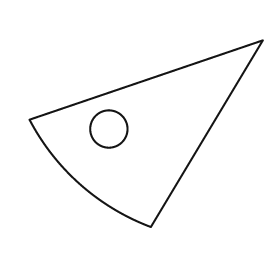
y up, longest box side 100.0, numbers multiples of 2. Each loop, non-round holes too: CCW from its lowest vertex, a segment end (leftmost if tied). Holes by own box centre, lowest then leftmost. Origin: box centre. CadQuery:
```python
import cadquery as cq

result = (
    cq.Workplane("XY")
    .moveTo(2.0, -40.0)
    .lineTo(50.0, 40.0)
    .lineTo(-50.0, 6.0)
    .threePointArc((-28.0, -22.0), (2.0, -40.0))
    .close()
    .moveTo(-16.0, 2.0)
    .circle(8.0)
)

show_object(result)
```